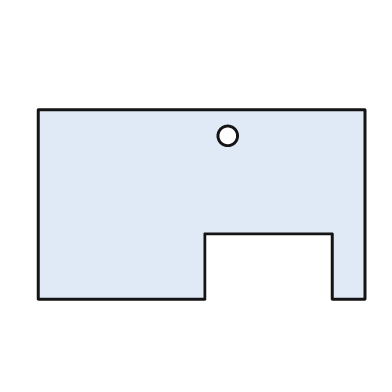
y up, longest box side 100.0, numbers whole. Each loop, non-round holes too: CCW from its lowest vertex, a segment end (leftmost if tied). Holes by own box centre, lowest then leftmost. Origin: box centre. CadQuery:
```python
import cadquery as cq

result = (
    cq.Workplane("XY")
    .moveTo(-50.0, -29.0)
    .lineTo(1.0, -29.0)
    .lineTo(1.0, -9.0)
    .lineTo(40.0, -9.0)
    .lineTo(40.0, -29.0)
    .lineTo(50.0, -29.0)
    .lineTo(50.0, 29.0)
    .lineTo(-50.0, 29.0)
    .close()
    .moveTo(8.0, 21.0)
    .circle(3.0)
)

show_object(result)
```